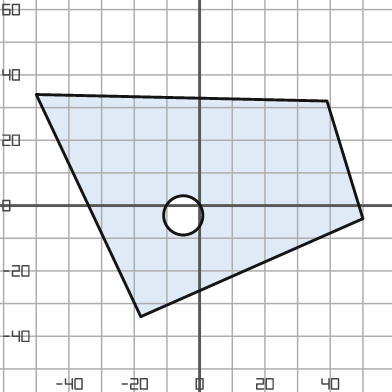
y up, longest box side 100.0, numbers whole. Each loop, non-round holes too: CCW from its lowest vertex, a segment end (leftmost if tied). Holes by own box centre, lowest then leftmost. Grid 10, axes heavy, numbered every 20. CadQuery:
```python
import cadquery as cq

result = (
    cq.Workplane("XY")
    .moveTo(-18.0, -34.0)
    .lineTo(50.0, -4.0)
    .lineTo(39.0, 32.0)
    .lineTo(-50.0, 34.0)
    .close()
    .moveTo(-5.0, -3.0)
    .circle(6.0)
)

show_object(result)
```